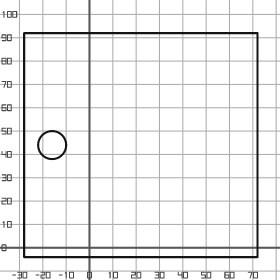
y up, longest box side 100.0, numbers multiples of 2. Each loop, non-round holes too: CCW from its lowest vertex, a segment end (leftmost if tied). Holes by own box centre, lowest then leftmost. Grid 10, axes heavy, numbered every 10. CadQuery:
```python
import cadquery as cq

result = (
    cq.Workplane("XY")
    .moveTo(-28.0, -4.0)
    .lineTo(72.0, -4.0)
    .lineTo(72.0, 92.0)
    .lineTo(-28.0, 92.0)
    .close()
    .moveTo(-16.0, 44.0)
    .circle(6.0)
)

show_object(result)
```